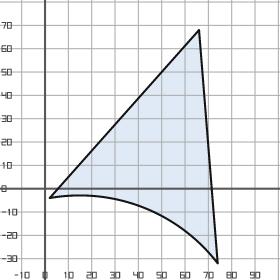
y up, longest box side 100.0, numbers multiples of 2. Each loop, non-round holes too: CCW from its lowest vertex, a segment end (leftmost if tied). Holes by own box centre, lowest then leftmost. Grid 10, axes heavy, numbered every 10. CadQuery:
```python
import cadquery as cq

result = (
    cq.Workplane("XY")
    .moveTo(74.0, -32.0)
    .lineTo(66.0, 68.0)
    .lineTo(2.0, -4.0)
    .threePointArc((42.0, -8.0), (74.0, -32.0))
    .close()
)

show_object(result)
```